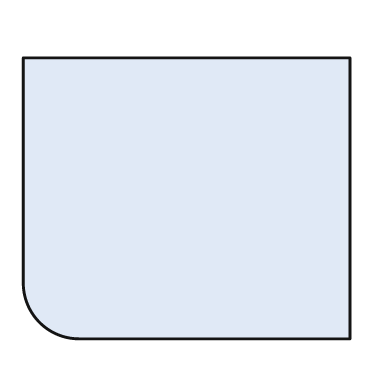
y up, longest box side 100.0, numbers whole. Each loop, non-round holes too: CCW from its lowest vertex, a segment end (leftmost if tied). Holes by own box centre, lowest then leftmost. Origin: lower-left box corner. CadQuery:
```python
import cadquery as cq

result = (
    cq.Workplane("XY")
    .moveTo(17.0, 0.0)
    .lineTo(100.0, 0.0)
    .lineTo(100.0, 86.0)
    .lineTo(0.0, 86.0)
    .lineTo(0.0, 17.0)
    .threePointArc((5.0, 5.0), (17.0, 0.0))
    .close()
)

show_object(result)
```